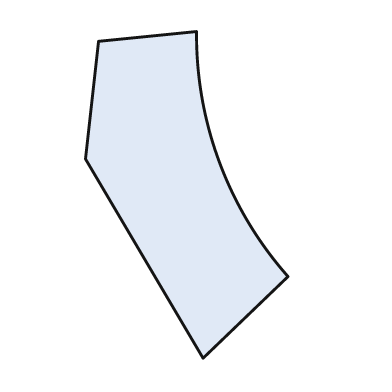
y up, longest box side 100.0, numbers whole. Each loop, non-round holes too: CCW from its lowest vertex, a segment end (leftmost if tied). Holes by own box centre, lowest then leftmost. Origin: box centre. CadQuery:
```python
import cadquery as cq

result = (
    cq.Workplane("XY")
    .moveTo(5.0, -50.0)
    .lineTo(31.0, -25.0)
    .threePointArc((10.0, 10.0), (3.0, 50.0))
    .lineTo(-27.0, 47.0)
    .lineTo(-31.0, 11.0)
    .close()
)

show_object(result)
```